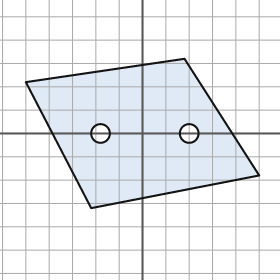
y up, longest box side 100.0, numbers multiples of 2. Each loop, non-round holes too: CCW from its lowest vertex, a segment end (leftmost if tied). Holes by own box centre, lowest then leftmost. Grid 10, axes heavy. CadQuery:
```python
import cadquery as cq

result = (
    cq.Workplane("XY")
    .moveTo(-22.0, -32.0)
    .lineTo(50.0, -18.0)
    .lineTo(18.0, 32.0)
    .lineTo(-50.0, 22.0)
    .close()
    .moveTo(-18.0, 0.0)
    .circle(4.0)
    .moveTo(20.0, 0.0)
    .circle(4.0)
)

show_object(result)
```